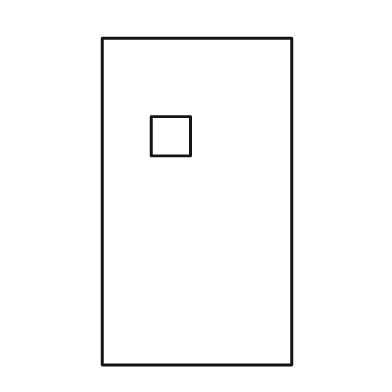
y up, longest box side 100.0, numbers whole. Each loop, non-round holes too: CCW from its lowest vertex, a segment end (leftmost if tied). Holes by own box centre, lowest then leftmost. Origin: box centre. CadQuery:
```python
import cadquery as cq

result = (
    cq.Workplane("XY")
    .moveTo(-29.0, -50.0)
    .lineTo(29.0, -50.0)
    .lineTo(29.0, 50.0)
    .lineTo(-29.0, 50.0)
    .close()
    .moveTo(-14.0, 14.0)
    .lineTo(-2.0, 14.0)
    .lineTo(-2.0, 26.0)
    .lineTo(-14.0, 26.0)
    .close()
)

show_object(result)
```